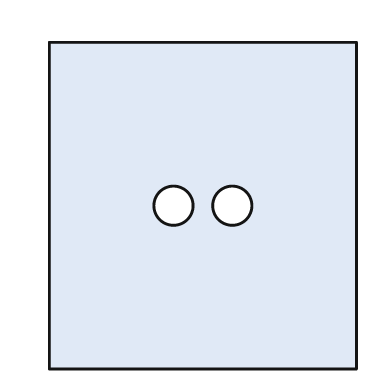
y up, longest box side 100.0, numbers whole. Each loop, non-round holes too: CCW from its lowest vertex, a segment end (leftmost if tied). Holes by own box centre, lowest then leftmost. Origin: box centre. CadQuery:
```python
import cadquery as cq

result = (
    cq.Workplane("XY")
    .moveTo(-47.0, -50.0)
    .lineTo(47.0, -50.0)
    .lineTo(47.0, 50.0)
    .lineTo(-47.0, 50.0)
    .close()
    .moveTo(-9.0, 0.0)
    .circle(6.0)
    .moveTo(9.0, 0.0)
    .circle(6.0)
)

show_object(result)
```